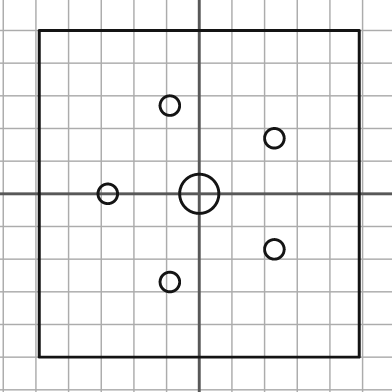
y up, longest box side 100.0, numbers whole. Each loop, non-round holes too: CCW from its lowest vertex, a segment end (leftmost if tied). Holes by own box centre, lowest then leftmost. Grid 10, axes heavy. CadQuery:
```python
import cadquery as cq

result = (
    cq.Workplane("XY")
    .moveTo(-49.0, -50.0)
    .lineTo(49.0, -50.0)
    .lineTo(49.0, 50.0)
    .lineTo(-49.0, 50.0)
    .close()
    .moveTo(-9.0, -27.0)
    .circle(3.0)
    .moveTo(23.0, -17.0)
    .circle(3.0)
    .moveTo(-28.0, 0.0)
    .circle(3.0)
    .moveTo(0.0, 0.0)
    .circle(6.0)
    .moveTo(23.0, 17.0)
    .circle(3.0)
    .moveTo(-9.0, 27.0)
    .circle(3.0)
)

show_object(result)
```